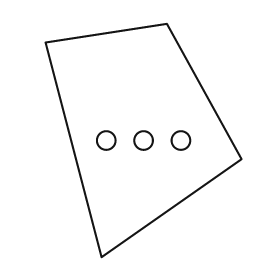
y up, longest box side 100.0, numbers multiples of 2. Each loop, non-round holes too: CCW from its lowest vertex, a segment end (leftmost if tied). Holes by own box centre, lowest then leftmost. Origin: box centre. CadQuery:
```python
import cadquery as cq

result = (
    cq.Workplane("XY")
    .moveTo(-18.0, -50.0)
    .lineTo(42.0, -8.0)
    .lineTo(10.0, 50.0)
    .lineTo(-42.0, 42.0)
    .close()
    .moveTo(-16.0, 0.0)
    .circle(4.0)
    .moveTo(0.0, 0.0)
    .circle(4.0)
    .moveTo(16.0, 0.0)
    .circle(4.0)
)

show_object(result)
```